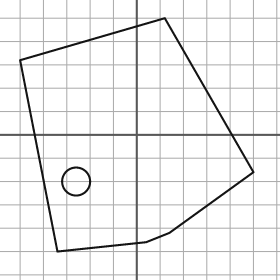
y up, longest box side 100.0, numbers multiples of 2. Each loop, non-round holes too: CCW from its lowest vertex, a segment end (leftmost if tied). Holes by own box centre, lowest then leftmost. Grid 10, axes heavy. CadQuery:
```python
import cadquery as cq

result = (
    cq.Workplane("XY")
    .moveTo(-34.0, -50.0)
    .lineTo(4.0, -46.0)
    .lineTo(14.0, -42.0)
    .lineTo(50.0, -16.0)
    .lineTo(12.0, 50.0)
    .lineTo(-50.0, 32.0)
    .close()
    .moveTo(-26.0, -20.0)
    .circle(6.0)
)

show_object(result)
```